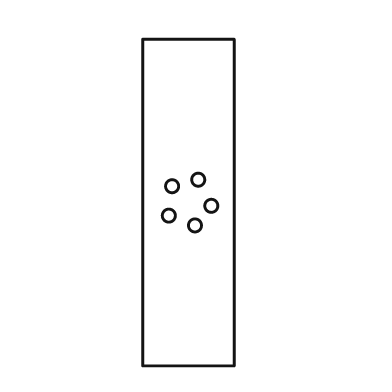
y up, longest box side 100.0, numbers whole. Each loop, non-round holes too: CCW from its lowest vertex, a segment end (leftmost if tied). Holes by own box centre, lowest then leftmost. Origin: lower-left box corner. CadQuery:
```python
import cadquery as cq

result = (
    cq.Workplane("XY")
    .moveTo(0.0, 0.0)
    .lineTo(28.0, 0.0)
    .lineTo(28.0, 100.0)
    .lineTo(0.0, 100.0)
    .close()
    .moveTo(16.0, 43.0)
    .circle(2.0)
    .moveTo(8.0, 46.0)
    .circle(2.0)
    .moveTo(21.0, 49.0)
    .circle(2.0)
    .moveTo(9.0, 55.0)
    .circle(2.0)
    .moveTo(17.0, 57.0)
    .circle(2.0)
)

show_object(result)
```